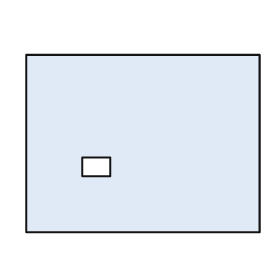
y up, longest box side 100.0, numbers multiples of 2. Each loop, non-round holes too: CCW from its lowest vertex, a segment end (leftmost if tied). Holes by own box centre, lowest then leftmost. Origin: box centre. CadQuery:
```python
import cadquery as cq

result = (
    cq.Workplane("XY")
    .moveTo(-50.0, -38.0)
    .lineTo(50.0, -38.0)
    .lineTo(50.0, 38.0)
    .lineTo(-50.0, 38.0)
    .close()
    .moveTo(-26.0, -14.0)
    .lineTo(-14.0, -14.0)
    .lineTo(-14.0, -6.0)
    .lineTo(-26.0, -6.0)
    .close()
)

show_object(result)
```